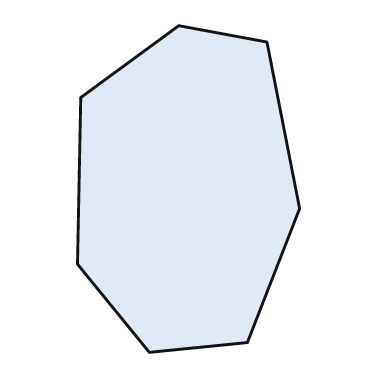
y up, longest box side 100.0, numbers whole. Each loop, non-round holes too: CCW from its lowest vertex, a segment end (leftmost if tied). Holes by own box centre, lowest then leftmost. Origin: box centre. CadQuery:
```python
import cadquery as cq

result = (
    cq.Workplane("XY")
    .moveTo(-12.0, -50.0)
    .lineTo(18.0, -47.0)
    .lineTo(34.0, -6.0)
    .lineTo(24.0, 45.0)
    .lineTo(-3.0, 50.0)
    .lineTo(-33.0, 28.0)
    .lineTo(-34.0, -23.0)
    .close()
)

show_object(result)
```